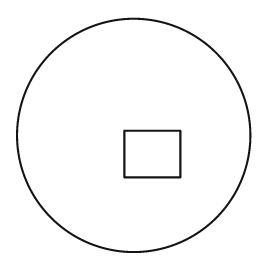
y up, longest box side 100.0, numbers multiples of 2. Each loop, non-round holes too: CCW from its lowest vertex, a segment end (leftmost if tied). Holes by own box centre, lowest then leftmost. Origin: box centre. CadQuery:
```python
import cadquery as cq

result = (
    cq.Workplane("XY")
    .moveTo(0.0, 0.0)
    .circle(50.0)
    .moveTo(-4.0, -18.0)
    .lineTo(20.0, -18.0)
    .lineTo(20.0, 2.0)
    .lineTo(-4.0, 2.0)
    .close()
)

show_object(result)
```